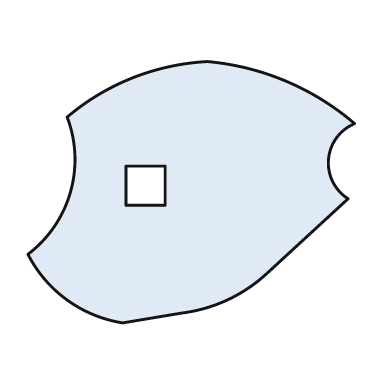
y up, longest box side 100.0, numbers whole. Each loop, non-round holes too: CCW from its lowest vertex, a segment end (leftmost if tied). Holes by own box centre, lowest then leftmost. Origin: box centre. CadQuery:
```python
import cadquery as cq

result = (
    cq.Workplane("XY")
    .moveTo(-21.0, -40.0)
    .lineTo(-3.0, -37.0)
    .threePointArc((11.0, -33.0), (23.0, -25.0))
    .lineTo(48.0, -2.0)
    .threePointArc((42.0, 10.0), (50.0, 21.0))
    .threePointArc((29.0, 34.0), (5.0, 40.0))
    .threePointArc((-18.0, 35.0), (-38.0, 23.0))
    .threePointArc((-37.0, 0.0), (-50.0, -19.0))
    .threePointArc((-38.0, -33.0), (-21.0, -40.0))
    .close()
    .moveTo(-20.0, -4.0)
    .lineTo(-8.0, -4.0)
    .lineTo(-8.0, 8.0)
    .lineTo(-20.0, 8.0)
    .close()
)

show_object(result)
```